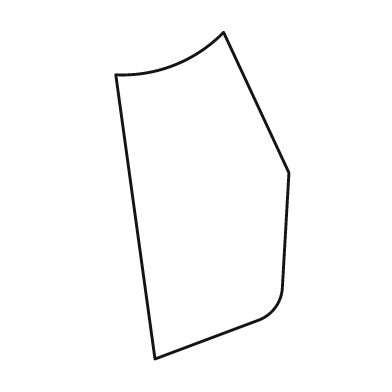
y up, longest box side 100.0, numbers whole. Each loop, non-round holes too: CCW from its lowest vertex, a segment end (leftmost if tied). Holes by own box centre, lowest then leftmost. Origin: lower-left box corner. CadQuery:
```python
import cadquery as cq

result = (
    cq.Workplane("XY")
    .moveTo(12.0, 0.0)
    .lineTo(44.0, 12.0)
    .threePointArc((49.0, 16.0), (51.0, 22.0))
    .lineTo(53.0, 57.0)
    .lineTo(33.0, 100.0)
    .threePointArc((18.0, 90.0), (0.0, 87.0))
    .close()
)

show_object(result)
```